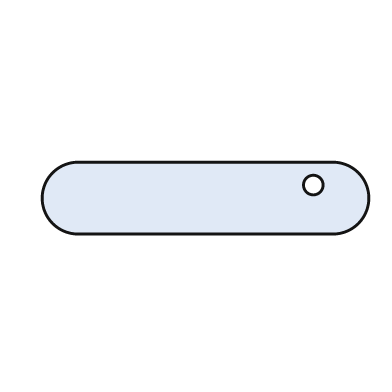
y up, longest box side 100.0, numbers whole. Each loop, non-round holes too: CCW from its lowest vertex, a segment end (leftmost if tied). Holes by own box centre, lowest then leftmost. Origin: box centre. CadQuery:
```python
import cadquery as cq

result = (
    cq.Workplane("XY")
    .moveTo(-39.0, -11.0)
    .lineTo(39.0, -11.0)
    .threePointArc((50.0, 0.0), (39.0, 11.0))
    .lineTo(-39.0, 11.0)
    .threePointArc((-50.0, 0.0), (-39.0, -11.0))
    .close()
    .moveTo(33.0, 4.0)
    .circle(3.0)
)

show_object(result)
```